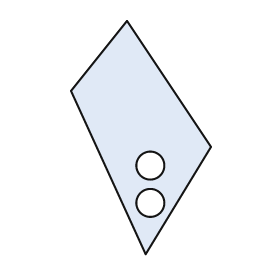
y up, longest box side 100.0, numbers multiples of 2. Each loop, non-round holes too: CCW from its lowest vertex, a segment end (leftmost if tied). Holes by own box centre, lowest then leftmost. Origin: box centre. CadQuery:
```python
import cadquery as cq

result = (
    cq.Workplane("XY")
    .moveTo(2.0, -50.0)
    .lineTo(30.0, -4.0)
    .lineTo(-6.0, 50.0)
    .lineTo(-30.0, 20.0)
    .close()
    .moveTo(4.0, -28.0)
    .circle(6.0)
    .moveTo(4.0, -12.0)
    .circle(6.0)
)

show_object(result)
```